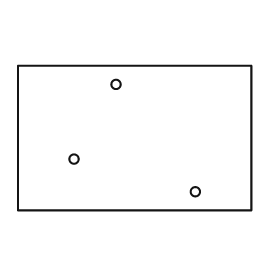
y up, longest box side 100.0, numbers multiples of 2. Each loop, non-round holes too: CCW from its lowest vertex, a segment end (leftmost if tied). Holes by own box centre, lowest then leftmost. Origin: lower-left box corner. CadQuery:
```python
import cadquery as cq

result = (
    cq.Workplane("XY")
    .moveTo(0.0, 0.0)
    .lineTo(100.0, 0.0)
    .lineTo(100.0, 62.0)
    .lineTo(0.0, 62.0)
    .close()
    .moveTo(76.0, 8.0)
    .circle(2.0)
    .moveTo(24.0, 22.0)
    .circle(2.0)
    .moveTo(42.0, 54.0)
    .circle(2.0)
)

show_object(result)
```